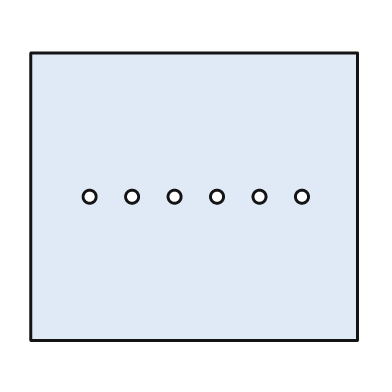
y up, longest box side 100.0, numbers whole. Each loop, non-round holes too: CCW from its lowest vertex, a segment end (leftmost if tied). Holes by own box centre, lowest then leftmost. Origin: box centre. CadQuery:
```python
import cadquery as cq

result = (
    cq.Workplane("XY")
    .moveTo(-50.0, -44.0)
    .lineTo(50.0, -44.0)
    .lineTo(50.0, 44.0)
    .lineTo(-50.0, 44.0)
    .close()
    .moveTo(-32.0, 0.0)
    .circle(2.0)
    .moveTo(-19.0, 0.0)
    .circle(2.0)
    .moveTo(-6.0, 0.0)
    .circle(2.0)
    .moveTo(7.0, 0.0)
    .circle(2.0)
    .moveTo(20.0, 0.0)
    .circle(2.0)
    .moveTo(33.0, 0.0)
    .circle(2.0)
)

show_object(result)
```